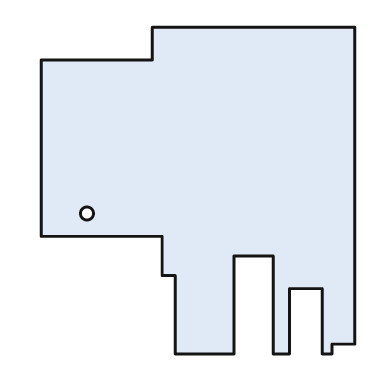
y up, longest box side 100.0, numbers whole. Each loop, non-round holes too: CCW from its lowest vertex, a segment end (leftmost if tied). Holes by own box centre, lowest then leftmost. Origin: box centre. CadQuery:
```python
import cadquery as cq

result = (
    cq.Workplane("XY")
    .moveTo(-7.0, -50.0)
    .lineTo(11.0, -50.0)
    .lineTo(11.0, -20.0)
    .lineTo(23.0, -20.0)
    .lineTo(23.0, -50.0)
    .lineTo(28.0, -50.0)
    .lineTo(28.0, -30.0)
    .lineTo(38.0, -30.0)
    .lineTo(38.0, -50.0)
    .lineTo(41.0, -50.0)
    .lineTo(41.0, -47.0)
    .lineTo(48.0, -47.0)
    .lineTo(48.0, 50.0)
    .lineTo(-14.0, 50.0)
    .lineTo(-14.0, 40.0)
    .lineTo(-48.0, 40.0)
    .lineTo(-48.0, -14.0)
    .lineTo(-11.0, -14.0)
    .lineTo(-11.0, -26.0)
    .lineTo(-7.0, -26.0)
    .close()
    .moveTo(-34.0, -7.0)
    .circle(2.0)
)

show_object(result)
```